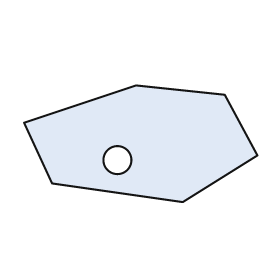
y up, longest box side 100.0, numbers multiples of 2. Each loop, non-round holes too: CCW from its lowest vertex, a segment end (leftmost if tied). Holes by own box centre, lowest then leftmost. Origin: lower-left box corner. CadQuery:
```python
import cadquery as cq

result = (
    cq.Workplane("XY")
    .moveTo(68.0, 0.0)
    .lineTo(100.0, 20.0)
    .lineTo(86.0, 46.0)
    .lineTo(48.0, 50.0)
    .lineTo(0.0, 34.0)
    .lineTo(12.0, 8.0)
    .close()
    .moveTo(40.0, 18.0)
    .circle(6.0)
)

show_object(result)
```